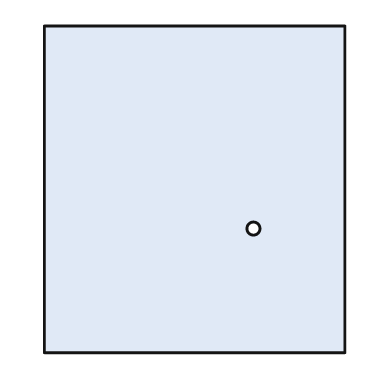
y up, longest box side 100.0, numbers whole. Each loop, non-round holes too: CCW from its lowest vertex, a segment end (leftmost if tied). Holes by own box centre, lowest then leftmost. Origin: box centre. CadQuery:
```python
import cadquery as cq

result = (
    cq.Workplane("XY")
    .moveTo(-46.0, -50.0)
    .lineTo(46.0, -50.0)
    .lineTo(46.0, 50.0)
    .lineTo(-46.0, 50.0)
    .close()
    .moveTo(18.0, -12.0)
    .circle(2.0)
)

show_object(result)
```